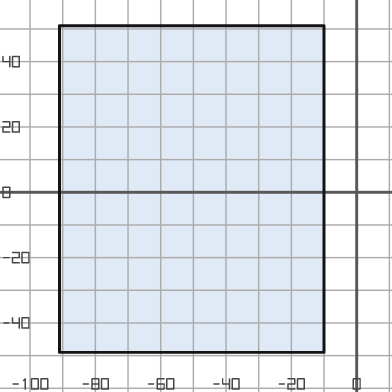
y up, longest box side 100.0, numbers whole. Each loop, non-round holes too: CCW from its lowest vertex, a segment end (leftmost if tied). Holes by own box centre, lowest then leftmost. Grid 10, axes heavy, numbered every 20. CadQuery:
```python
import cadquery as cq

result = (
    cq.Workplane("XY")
    .moveTo(-91.0, -49.0)
    .lineTo(-10.0, -49.0)
    .lineTo(-10.0, 51.0)
    .lineTo(-91.0, 51.0)
    .close()
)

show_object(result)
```